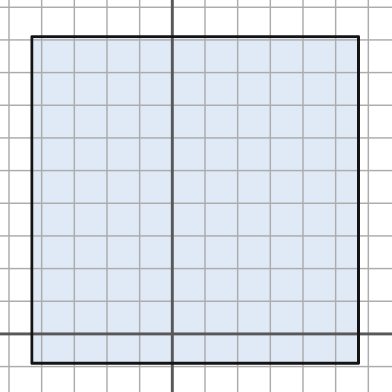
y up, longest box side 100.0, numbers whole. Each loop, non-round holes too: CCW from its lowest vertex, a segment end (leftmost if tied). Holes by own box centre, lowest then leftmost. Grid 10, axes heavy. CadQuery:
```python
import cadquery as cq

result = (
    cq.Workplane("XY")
    .moveTo(-43.0, -9.0)
    .lineTo(57.0, -9.0)
    .lineTo(57.0, 91.0)
    .lineTo(-43.0, 91.0)
    .close()
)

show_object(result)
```